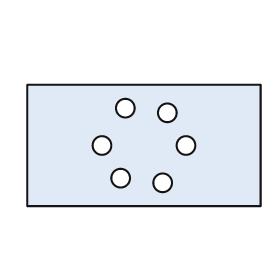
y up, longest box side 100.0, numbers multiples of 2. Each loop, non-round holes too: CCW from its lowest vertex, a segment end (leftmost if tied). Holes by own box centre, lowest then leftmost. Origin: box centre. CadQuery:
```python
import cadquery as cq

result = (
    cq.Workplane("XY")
    .moveTo(-50.0, -26.0)
    .lineTo(50.0, -26.0)
    .lineTo(50.0, 26.0)
    .lineTo(-50.0, 26.0)
    .close()
    .moveTo(8.0, -16.0)
    .circle(4.0)
    .moveTo(-10.0, -14.0)
    .circle(4.0)
    .moveTo(-18.0, 0.0)
    .circle(4.0)
    .moveTo(18.0, 0.0)
    .circle(4.0)
    .moveTo(10.0, 14.0)
    .circle(4.0)
    .moveTo(-8.0, 16.0)
    .circle(4.0)
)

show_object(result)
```